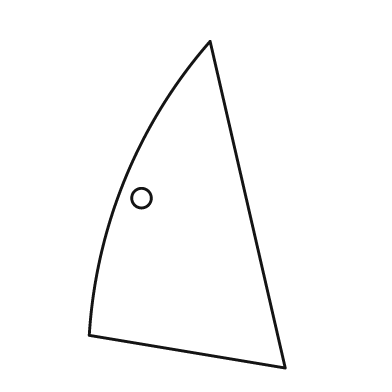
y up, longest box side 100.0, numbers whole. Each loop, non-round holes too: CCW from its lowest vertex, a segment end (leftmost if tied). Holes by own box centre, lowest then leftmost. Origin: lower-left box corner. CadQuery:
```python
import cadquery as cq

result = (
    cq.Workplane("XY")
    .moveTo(60.0, 0.0)
    .lineTo(37.0, 100.0)
    .threePointArc((11.0, 58.0), (0.0, 10.0))
    .close()
    .moveTo(16.0, 52.0)
    .circle(3.0)
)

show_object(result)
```